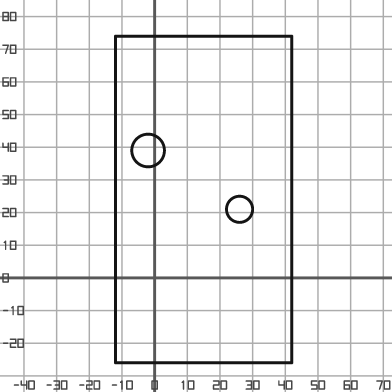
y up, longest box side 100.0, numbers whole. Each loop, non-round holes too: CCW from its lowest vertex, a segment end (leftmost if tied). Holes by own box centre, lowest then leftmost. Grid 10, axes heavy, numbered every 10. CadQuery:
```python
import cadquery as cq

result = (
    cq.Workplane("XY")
    .moveTo(-12.0, -26.0)
    .lineTo(42.0, -26.0)
    .lineTo(42.0, 74.0)
    .lineTo(-12.0, 74.0)
    .close()
    .moveTo(26.0, 21.0)
    .circle(4.0)
    .moveTo(-2.0, 39.0)
    .circle(5.0)
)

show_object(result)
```